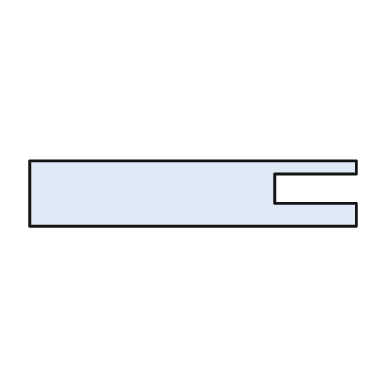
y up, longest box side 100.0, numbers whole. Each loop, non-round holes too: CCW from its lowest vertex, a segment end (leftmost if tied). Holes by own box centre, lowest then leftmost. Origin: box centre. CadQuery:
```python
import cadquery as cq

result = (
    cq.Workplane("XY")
    .moveTo(-50.0, -10.0)
    .lineTo(50.0, -10.0)
    .lineTo(50.0, -3.0)
    .lineTo(25.0, -3.0)
    .lineTo(25.0, 6.0)
    .lineTo(50.0, 6.0)
    .lineTo(50.0, 10.0)
    .lineTo(-50.0, 10.0)
    .close()
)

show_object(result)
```